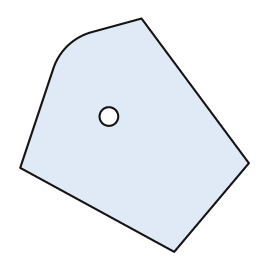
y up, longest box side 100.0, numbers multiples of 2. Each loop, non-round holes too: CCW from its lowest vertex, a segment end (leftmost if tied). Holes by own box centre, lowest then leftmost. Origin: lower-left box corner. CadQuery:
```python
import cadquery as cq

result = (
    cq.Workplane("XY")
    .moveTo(66.0, 0.0)
    .lineTo(98.0, 38.0)
    .lineTo(52.0, 100.0)
    .lineTo(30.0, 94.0)
    .threePointArc((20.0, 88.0), (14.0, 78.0))
    .lineTo(0.0, 36.0)
    .close()
    .moveTo(38.0, 58.0)
    .circle(4.0)
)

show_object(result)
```